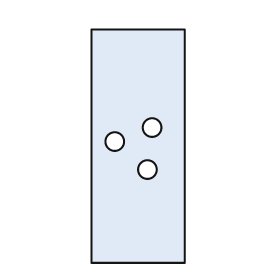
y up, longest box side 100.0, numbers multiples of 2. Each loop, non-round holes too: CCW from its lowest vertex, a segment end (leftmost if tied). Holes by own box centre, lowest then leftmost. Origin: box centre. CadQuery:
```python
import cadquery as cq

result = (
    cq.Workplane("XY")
    .moveTo(-20.0, -50.0)
    .lineTo(20.0, -50.0)
    .lineTo(20.0, 50.0)
    .lineTo(-20.0, 50.0)
    .close()
    .moveTo(4.0, -10.0)
    .circle(4.0)
    .moveTo(-10.0, 2.0)
    .circle(4.0)
    .moveTo(6.0, 8.0)
    .circle(4.0)
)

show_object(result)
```